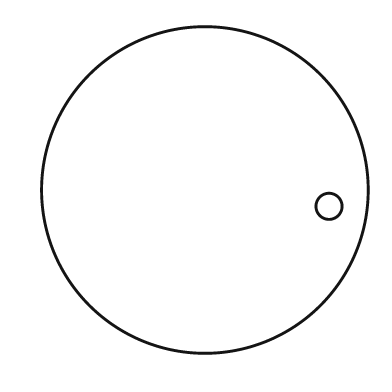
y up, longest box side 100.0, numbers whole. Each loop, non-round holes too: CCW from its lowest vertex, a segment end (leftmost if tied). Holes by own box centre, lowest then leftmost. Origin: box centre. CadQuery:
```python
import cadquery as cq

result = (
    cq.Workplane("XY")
    .moveTo(0.0, 0.0)
    .circle(50.0)
    .moveTo(38.0, -5.0)
    .circle(4.0)
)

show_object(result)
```